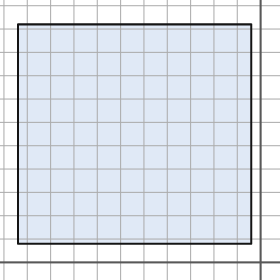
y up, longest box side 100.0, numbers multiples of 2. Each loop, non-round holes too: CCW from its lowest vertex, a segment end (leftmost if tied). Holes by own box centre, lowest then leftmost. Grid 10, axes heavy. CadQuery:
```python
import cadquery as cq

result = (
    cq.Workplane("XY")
    .moveTo(-104.0, 8.0)
    .lineTo(-4.0, 8.0)
    .lineTo(-4.0, 102.0)
    .lineTo(-104.0, 102.0)
    .close()
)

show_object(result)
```